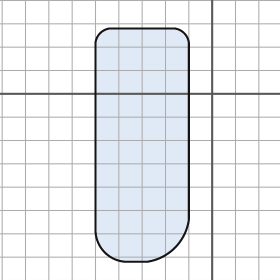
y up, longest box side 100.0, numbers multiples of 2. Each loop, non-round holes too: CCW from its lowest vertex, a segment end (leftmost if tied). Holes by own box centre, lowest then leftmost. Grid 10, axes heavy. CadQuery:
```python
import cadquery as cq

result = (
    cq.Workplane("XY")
    .moveTo(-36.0, -72.0)
    .lineTo(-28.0, -72.0)
    .threePointArc((-16.0, -66.0), (-10.0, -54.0))
    .lineTo(-10.0, 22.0)
    .threePointArc((-12.0, 26.0), (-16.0, 28.0))
    .lineTo(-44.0, 28.0)
    .threePointArc((-48.0, 26.0), (-50.0, 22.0))
    .lineTo(-50.0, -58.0)
    .threePointArc((-46.0, -68.0), (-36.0, -72.0))
    .close()
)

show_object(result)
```